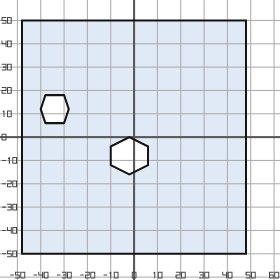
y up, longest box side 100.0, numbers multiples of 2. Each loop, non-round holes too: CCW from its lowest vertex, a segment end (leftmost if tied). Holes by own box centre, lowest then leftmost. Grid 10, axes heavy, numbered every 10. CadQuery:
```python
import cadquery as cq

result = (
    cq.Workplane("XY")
    .moveTo(-48.0, -50.0)
    .lineTo(48.0, -50.0)
    .lineTo(48.0, 50.0)
    .lineTo(-48.0, 50.0)
    .close()
    .moveTo(-2.0, -16.0)
    .lineTo(6.0, -12.0)
    .lineTo(6.0, -4.0)
    .lineTo(-2.0, 0.0)
    .lineTo(-10.0, -4.0)
    .lineTo(-10.0, -12.0)
    .close()
    .moveTo(-38.0, 6.0)
    .lineTo(-30.0, 6.0)
    .lineTo(-28.0, 12.0)
    .lineTo(-30.0, 18.0)
    .lineTo(-38.0, 18.0)
    .lineTo(-40.0, 12.0)
    .close()
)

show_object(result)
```